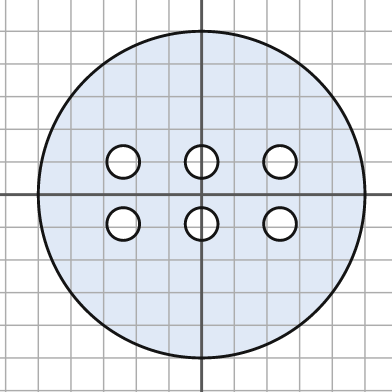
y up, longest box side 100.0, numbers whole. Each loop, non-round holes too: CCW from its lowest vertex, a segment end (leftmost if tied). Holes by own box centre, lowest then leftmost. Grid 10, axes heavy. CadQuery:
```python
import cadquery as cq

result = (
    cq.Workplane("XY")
    .moveTo(0.0, 0.0)
    .circle(50.0)
    .moveTo(-24.0, -9.0)
    .circle(5.0)
    .moveTo(0.0, -9.0)
    .circle(5.0)
    .moveTo(24.0, -9.0)
    .circle(5.0)
    .moveTo(-24.0, 10.0)
    .circle(5.0)
    .moveTo(0.0, 10.0)
    .circle(5.0)
    .moveTo(24.0, 10.0)
    .circle(5.0)
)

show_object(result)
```